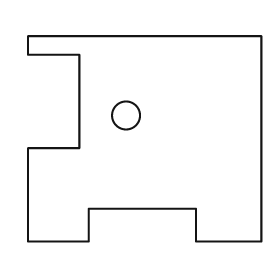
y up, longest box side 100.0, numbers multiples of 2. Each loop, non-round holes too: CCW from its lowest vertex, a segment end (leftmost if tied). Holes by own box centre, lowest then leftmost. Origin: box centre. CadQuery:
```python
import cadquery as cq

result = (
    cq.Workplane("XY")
    .moveTo(-50.0, -44.0)
    .lineTo(-24.0, -44.0)
    .lineTo(-24.0, -30.0)
    .lineTo(22.0, -30.0)
    .lineTo(22.0, -44.0)
    .lineTo(50.0, -44.0)
    .lineTo(50.0, 44.0)
    .lineTo(-50.0, 44.0)
    .lineTo(-50.0, 36.0)
    .lineTo(-28.0, 36.0)
    .lineTo(-28.0, -4.0)
    .lineTo(-50.0, -4.0)
    .close()
    .moveTo(-8.0, 10.0)
    .circle(6.0)
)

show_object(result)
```